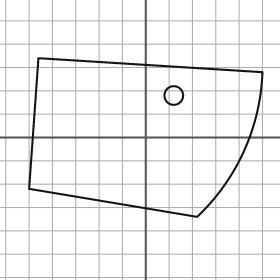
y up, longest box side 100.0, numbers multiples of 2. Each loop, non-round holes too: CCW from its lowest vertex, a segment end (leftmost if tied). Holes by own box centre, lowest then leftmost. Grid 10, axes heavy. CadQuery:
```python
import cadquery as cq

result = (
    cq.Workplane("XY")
    .moveTo(22.0, -34.0)
    .threePointArc((42.0, -6.0), (50.0, 28.0))
    .lineTo(-46.0, 34.0)
    .lineTo(-50.0, -22.0)
    .close()
    .moveTo(12.0, 18.0)
    .circle(4.0)
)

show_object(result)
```